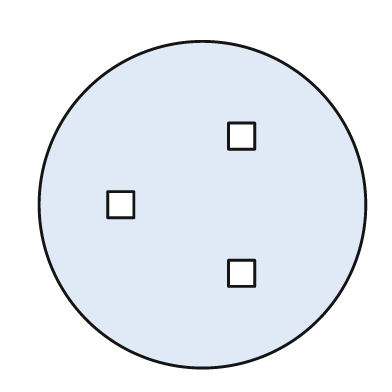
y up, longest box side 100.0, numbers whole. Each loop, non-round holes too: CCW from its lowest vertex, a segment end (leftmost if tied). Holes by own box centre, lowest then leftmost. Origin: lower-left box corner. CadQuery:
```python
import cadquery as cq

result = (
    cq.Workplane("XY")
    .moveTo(50.0, 50.0)
    .circle(50.0)
    .moveTo(58.0, 25.0)
    .lineTo(66.0, 25.0)
    .lineTo(66.0, 33.0)
    .lineTo(58.0, 33.0)
    .close()
    .moveTo(21.0, 46.0)
    .lineTo(29.0, 46.0)
    .lineTo(29.0, 54.0)
    .lineTo(21.0, 54.0)
    .close()
    .moveTo(58.0, 67.0)
    .lineTo(66.0, 67.0)
    .lineTo(66.0, 75.0)
    .lineTo(58.0, 75.0)
    .close()
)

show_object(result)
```